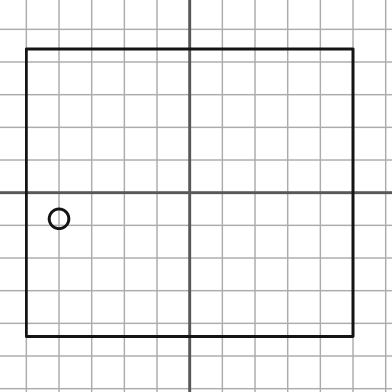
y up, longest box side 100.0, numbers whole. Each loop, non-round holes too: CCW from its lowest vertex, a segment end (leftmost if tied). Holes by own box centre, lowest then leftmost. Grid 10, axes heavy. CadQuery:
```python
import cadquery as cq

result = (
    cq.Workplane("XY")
    .moveTo(-50.0, -44.0)
    .lineTo(50.0, -44.0)
    .lineTo(50.0, 44.0)
    .lineTo(-50.0, 44.0)
    .close()
    .moveTo(-40.0, -8.0)
    .circle(3.0)
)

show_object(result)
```